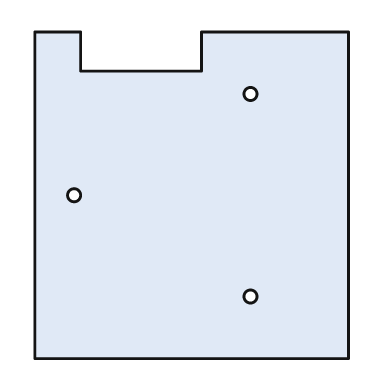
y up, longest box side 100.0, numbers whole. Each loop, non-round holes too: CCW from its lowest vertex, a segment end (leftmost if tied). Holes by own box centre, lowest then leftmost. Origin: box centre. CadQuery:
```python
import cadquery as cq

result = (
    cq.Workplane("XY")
    .moveTo(-48.0, -50.0)
    .lineTo(48.0, -50.0)
    .lineTo(48.0, 50.0)
    .lineTo(3.0, 50.0)
    .lineTo(3.0, 38.0)
    .lineTo(-34.0, 38.0)
    .lineTo(-34.0, 50.0)
    .lineTo(-48.0, 50.0)
    .close()
    .moveTo(18.0, -31.0)
    .circle(2.0)
    .moveTo(-36.0, 0.0)
    .circle(2.0)
    .moveTo(18.0, 31.0)
    .circle(2.0)
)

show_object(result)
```